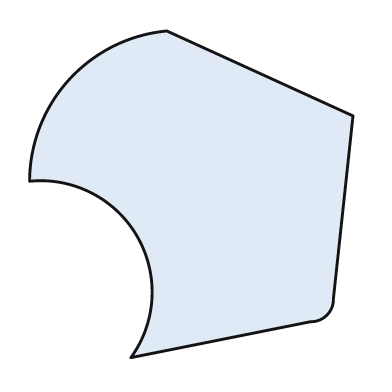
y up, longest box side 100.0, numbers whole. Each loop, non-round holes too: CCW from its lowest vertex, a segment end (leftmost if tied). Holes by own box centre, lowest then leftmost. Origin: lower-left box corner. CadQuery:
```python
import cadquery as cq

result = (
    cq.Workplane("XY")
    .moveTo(31.0, 0.0)
    .lineTo(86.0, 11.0)
    .threePointArc((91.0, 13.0), (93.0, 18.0))
    .lineTo(99.0, 74.0)
    .lineTo(42.0, 100.0)
    .threePointArc((12.0, 85.0), (0.0, 54.0))
    .threePointArc((33.0, 37.0), (31.0, 0.0))
    .close()
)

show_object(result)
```